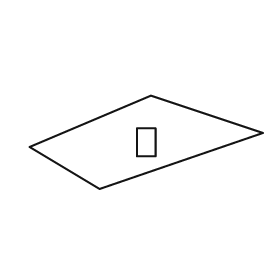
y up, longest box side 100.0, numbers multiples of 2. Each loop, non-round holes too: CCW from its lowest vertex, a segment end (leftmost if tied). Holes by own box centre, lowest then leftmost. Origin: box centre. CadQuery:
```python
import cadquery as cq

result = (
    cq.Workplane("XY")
    .moveTo(-20.0, -20.0)
    .lineTo(50.0, 4.0)
    .lineTo(2.0, 20.0)
    .lineTo(-50.0, -2.0)
    .close()
    .moveTo(-4.0, -6.0)
    .lineTo(4.0, -6.0)
    .lineTo(4.0, 6.0)
    .lineTo(-4.0, 6.0)
    .close()
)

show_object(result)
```